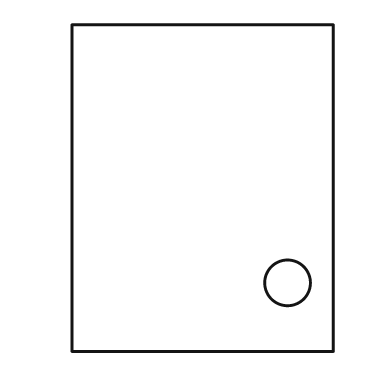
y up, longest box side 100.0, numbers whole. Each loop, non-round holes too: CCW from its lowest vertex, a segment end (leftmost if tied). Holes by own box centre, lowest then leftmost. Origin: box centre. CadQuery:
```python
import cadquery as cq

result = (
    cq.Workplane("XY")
    .moveTo(-40.0, -50.0)
    .lineTo(40.0, -50.0)
    .lineTo(40.0, 50.0)
    .lineTo(-40.0, 50.0)
    .close()
    .moveTo(26.0, -29.0)
    .circle(7.0)
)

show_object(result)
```